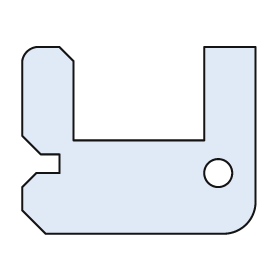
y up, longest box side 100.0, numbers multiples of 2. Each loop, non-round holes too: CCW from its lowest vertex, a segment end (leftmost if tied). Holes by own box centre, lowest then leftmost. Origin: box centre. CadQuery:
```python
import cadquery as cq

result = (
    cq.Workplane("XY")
    .moveTo(-40.0, -40.0)
    .lineTo(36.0, -40.0)
    .threePointArc((46.0, -36.0), (50.0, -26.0))
    .lineTo(50.0, 40.0)
    .lineTo(28.0, 40.0)
    .lineTo(28.0, 0.0)
    .lineTo(-28.0, 0.0)
    .lineTo(-28.0, 34.0)
    .lineTo(-34.0, 40.0)
    .lineTo(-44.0, 40.0)
    .threePointArc((-48.0, 38.0), (-50.0, 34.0))
    .lineTo(-50.0, 2.0)
    .lineTo(-42.0, -6.0)
    .lineTo(-34.0, -6.0)
    .lineTo(-34.0, -14.0)
    .lineTo(-44.0, -14.0)
    .lineTo(-50.0, -20.0)
    .lineTo(-50.0, -30.0)
    .close()
    .moveTo(34.0, -14.0)
    .circle(6.0)
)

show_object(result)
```